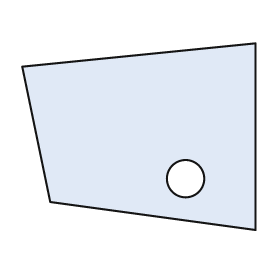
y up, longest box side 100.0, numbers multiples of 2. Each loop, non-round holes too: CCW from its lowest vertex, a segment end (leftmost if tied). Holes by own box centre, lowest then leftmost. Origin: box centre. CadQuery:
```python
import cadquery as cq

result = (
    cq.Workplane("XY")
    .moveTo(50.0, -40.0)
    .lineTo(50.0, 40.0)
    .lineTo(-50.0, 30.0)
    .lineTo(-38.0, -28.0)
    .close()
    .moveTo(20.0, -18.0)
    .circle(8.0)
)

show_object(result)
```